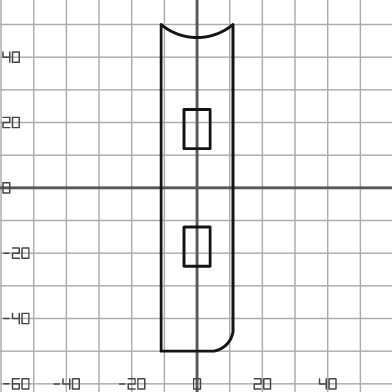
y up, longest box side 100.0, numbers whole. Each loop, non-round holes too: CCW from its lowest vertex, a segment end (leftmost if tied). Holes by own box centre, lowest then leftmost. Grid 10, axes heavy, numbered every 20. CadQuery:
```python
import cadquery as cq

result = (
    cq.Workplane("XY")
    .moveTo(-11.0, -50.0)
    .lineTo(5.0, -50.0)
    .threePointArc((9.0, -48.0), (11.0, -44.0))
    .lineTo(11.0, 50.0)
    .threePointArc((0.0, 46.0), (-11.0, 50.0))
    .close()
    .moveTo(-4.0, -24.0)
    .lineTo(4.0, -24.0)
    .lineTo(4.0, -12.0)
    .lineTo(-4.0, -12.0)
    .close()
    .moveTo(-4.0, 12.0)
    .lineTo(4.0, 12.0)
    .lineTo(4.0, 24.0)
    .lineTo(-4.0, 24.0)
    .close()
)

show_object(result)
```